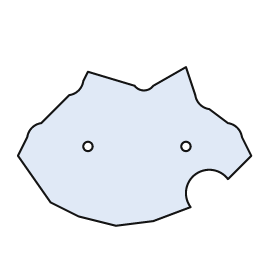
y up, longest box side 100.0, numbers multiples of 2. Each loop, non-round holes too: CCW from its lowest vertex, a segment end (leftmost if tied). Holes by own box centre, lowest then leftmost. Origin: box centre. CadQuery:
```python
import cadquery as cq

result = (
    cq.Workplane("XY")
    .moveTo(-8.0, -34.0)
    .lineTo(8.0, -32.0)
    .lineTo(24.0, -26.0)
    .threePointArc((26.0, -12.0), (40.0, -14.0))
    .lineTo(50.0, -4.0)
    .lineTo(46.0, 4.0)
    .threePointArc((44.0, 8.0), (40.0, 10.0))
    .lineTo(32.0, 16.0)
    .threePointArc((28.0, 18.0), (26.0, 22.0))
    .lineTo(22.0, 34.0)
    .lineTo(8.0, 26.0)
    .threePointArc((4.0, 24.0), (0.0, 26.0))
    .lineTo(-20.0, 32.0)
    .lineTo(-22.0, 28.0)
    .threePointArc((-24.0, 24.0), (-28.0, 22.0))
    .lineTo(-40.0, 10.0)
    .threePointArc((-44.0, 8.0), (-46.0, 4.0))
    .lineTo(-50.0, -4.0)
    .lineTo(-36.0, -24.0)
    .lineTo(-24.0, -30.0)
    .close()
    .moveTo(-20.0, 0.0)
    .circle(2.0)
    .moveTo(22.0, 0.0)
    .circle(2.0)
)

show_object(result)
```